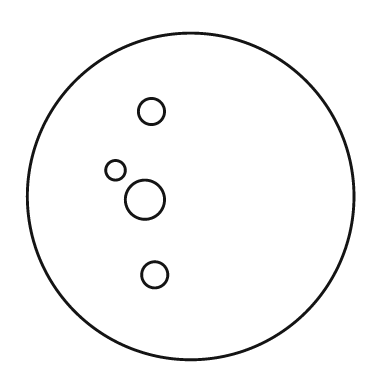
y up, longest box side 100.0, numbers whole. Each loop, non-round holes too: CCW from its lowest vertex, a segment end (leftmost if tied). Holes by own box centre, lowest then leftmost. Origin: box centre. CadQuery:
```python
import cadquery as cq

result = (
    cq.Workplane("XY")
    .moveTo(0.0, 0.0)
    .circle(50.0)
    .moveTo(-11.0, -24.0)
    .circle(4.0)
    .moveTo(-14.0, -1.0)
    .circle(6.0)
    .moveTo(-23.0, 8.0)
    .circle(3.0)
    .moveTo(-12.0, 26.0)
    .circle(4.0)
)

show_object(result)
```